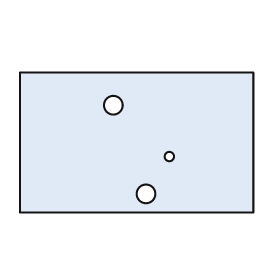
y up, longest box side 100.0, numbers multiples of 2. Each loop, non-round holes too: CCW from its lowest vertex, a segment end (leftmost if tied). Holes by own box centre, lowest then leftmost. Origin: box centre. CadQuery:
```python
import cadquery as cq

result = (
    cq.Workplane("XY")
    .moveTo(-50.0, -30.0)
    .lineTo(50.0, -30.0)
    .lineTo(50.0, 30.0)
    .lineTo(-50.0, 30.0)
    .close()
    .moveTo(4.0, -22.0)
    .circle(4.0)
    .moveTo(14.0, -6.0)
    .circle(2.0)
    .moveTo(-10.0, 16.0)
    .circle(4.0)
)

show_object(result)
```